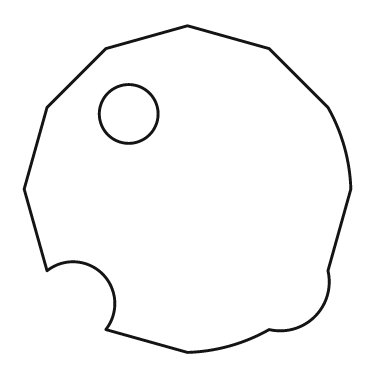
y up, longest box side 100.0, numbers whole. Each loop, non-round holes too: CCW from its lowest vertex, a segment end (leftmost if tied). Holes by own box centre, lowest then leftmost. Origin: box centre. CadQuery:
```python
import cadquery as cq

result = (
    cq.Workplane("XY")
    .moveTo(0.0, -50.0)
    .threePointArc((13.0, -48.0), (25.0, -43.0))
    .threePointArc((39.0, -39.0), (43.0, -25.0))
    .lineTo(50.0, 0.0)
    .threePointArc((48.0, 13.0), (43.0, 25.0))
    .lineTo(25.0, 43.0)
    .lineTo(0.0, 50.0)
    .lineTo(-25.0, 43.0)
    .lineTo(-43.0, 25.0)
    .lineTo(-50.0, 0.0)
    .lineTo(-43.0, -25.0)
    .threePointArc((-26.0, -26.0), (-25.0, -43.0))
    .close()
    .moveTo(-18.0, 23.0)
    .circle(9.0)
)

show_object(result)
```